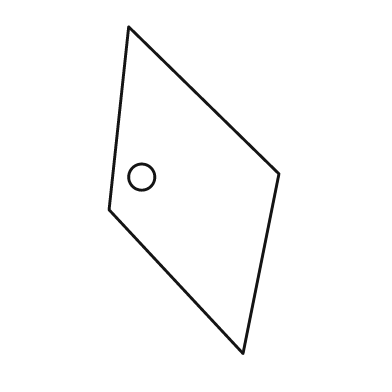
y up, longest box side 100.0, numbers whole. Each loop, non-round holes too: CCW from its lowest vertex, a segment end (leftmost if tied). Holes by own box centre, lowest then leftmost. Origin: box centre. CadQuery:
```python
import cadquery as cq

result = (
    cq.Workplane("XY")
    .moveTo(15.0, -50.0)
    .lineTo(26.0, 5.0)
    .lineTo(-20.0, 50.0)
    .lineTo(-26.0, -6.0)
    .close()
    .moveTo(-16.0, 4.0)
    .circle(4.0)
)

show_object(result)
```